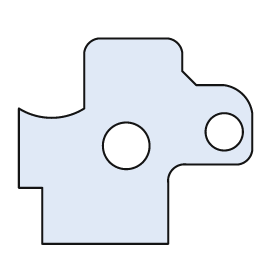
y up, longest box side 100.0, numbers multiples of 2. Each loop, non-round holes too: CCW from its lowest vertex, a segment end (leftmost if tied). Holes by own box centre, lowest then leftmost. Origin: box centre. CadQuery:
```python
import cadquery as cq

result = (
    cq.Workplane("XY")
    .moveTo(-40.0, -44.0)
    .lineTo(14.0, -44.0)
    .lineTo(14.0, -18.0)
    .threePointArc((16.0, -12.0), (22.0, -10.0))
    .lineTo(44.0, -10.0)
    .threePointArc((48.0, -8.0), (50.0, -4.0))
    .lineTo(50.0, 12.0)
    .threePointArc((46.0, 20.0), (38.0, 24.0))
    .lineTo(26.0, 24.0)
    .lineTo(20.0, 30.0)
    .lineTo(20.0, 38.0)
    .threePointArc((18.0, 42.0), (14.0, 44.0))
    .lineTo(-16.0, 44.0)
    .threePointArc((-20.0, 42.0), (-22.0, 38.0))
    .lineTo(-22.0, 14.0)
    .threePointArc((-36.0, 10.0), (-50.0, 14.0))
    .lineTo(-50.0, -20.0)
    .lineTo(-40.0, -20.0)
    .close()
    .moveTo(-4.0, -2.0)
    .circle(10.0)
    .moveTo(38.0, 4.0)
    .circle(8.0)
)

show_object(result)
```